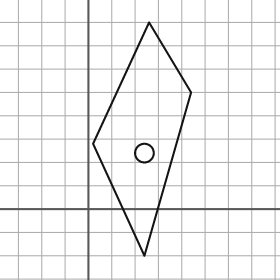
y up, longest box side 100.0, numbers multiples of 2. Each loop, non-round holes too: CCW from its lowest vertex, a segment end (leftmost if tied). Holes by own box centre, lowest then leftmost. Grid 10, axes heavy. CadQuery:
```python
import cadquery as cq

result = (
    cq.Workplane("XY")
    .moveTo(24.0, -20.0)
    .lineTo(44.0, 50.0)
    .lineTo(26.0, 80.0)
    .lineTo(2.0, 28.0)
    .close()
    .moveTo(24.0, 24.0)
    .circle(4.0)
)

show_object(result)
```